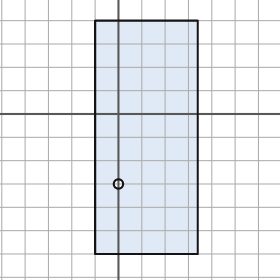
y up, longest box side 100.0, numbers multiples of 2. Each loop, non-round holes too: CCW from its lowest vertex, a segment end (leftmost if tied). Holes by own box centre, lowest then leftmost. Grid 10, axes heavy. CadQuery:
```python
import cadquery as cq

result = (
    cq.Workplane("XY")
    .moveTo(-10.0, -60.0)
    .lineTo(34.0, -60.0)
    .lineTo(34.0, 40.0)
    .lineTo(-10.0, 40.0)
    .close()
    .moveTo(0.0, -30.0)
    .circle(2.0)
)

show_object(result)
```